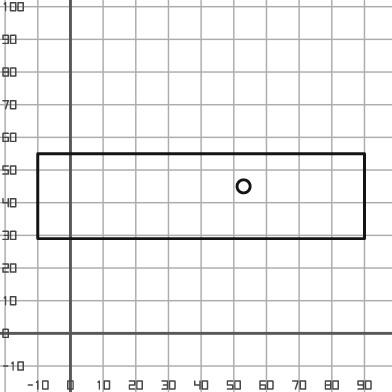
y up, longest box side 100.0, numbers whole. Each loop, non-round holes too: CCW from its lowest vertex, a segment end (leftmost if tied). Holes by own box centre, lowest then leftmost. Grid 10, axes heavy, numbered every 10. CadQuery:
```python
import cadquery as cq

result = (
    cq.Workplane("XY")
    .moveTo(-10.0, 29.0)
    .lineTo(90.0, 29.0)
    .lineTo(90.0, 55.0)
    .lineTo(-10.0, 55.0)
    .close()
    .moveTo(53.0, 45.0)
    .circle(2.0)
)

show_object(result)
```